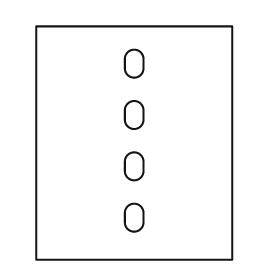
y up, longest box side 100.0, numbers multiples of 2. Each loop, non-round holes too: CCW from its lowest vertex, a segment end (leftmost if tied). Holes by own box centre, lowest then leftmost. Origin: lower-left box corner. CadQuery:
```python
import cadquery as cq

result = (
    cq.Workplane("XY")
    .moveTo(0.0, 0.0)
    .lineTo(84.0, 0.0)
    .lineTo(84.0, 100.0)
    .lineTo(0.0, 100.0)
    .close()
    .moveTo(38.0, 16.0)
    .threePointArc((42.0, 12.0), (46.0, 16.0))
    .lineTo(46.0, 20.0)
    .threePointArc((42.0, 24.0), (38.0, 20.0))
    .close()
    .moveTo(38.0, 38.0)
    .threePointArc((42.0, 34.0), (46.0, 38.0))
    .lineTo(46.0, 42.0)
    .threePointArc((42.0, 46.0), (38.0, 42.0))
    .close()
    .moveTo(38.0, 60.0)
    .threePointArc((42.0, 56.0), (46.0, 60.0))
    .lineTo(46.0, 64.0)
    .threePointArc((42.0, 68.0), (38.0, 64.0))
    .close()
    .moveTo(38.0, 82.0)
    .threePointArc((42.0, 78.0), (46.0, 82.0))
    .lineTo(46.0, 86.0)
    .threePointArc((42.0, 90.0), (38.0, 86.0))
    .close()
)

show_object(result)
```